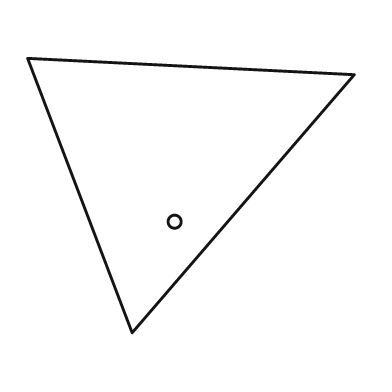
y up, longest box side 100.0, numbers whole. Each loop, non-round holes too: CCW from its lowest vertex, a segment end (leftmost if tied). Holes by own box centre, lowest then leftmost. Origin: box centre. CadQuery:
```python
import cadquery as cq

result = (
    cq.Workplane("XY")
    .moveTo(-18.0, -42.0)
    .lineTo(50.0, 37.0)
    .lineTo(-50.0, 42.0)
    .close()
    .moveTo(-5.0, -8.0)
    .circle(2.0)
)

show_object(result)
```